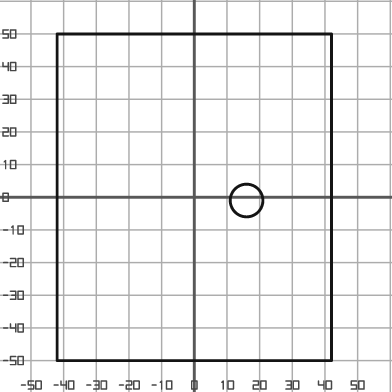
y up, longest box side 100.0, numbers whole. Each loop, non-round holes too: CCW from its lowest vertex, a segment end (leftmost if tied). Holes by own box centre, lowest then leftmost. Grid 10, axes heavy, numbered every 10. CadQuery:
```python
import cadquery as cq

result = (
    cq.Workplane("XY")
    .moveTo(-42.0, -50.0)
    .lineTo(42.0, -50.0)
    .lineTo(42.0, 50.0)
    .lineTo(-42.0, 50.0)
    .close()
    .moveTo(16.0, -1.0)
    .circle(5.0)
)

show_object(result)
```